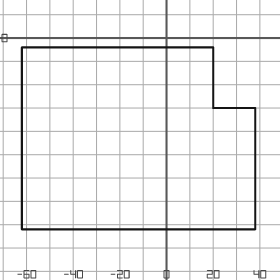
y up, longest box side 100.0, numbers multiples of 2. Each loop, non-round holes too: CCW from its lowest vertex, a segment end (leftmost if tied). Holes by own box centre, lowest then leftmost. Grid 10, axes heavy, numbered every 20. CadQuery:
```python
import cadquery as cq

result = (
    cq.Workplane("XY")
    .moveTo(-62.0, -82.0)
    .lineTo(38.0, -82.0)
    .lineTo(38.0, -30.0)
    .lineTo(20.0, -30.0)
    .lineTo(20.0, -4.0)
    .lineTo(-62.0, -4.0)
    .close()
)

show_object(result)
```